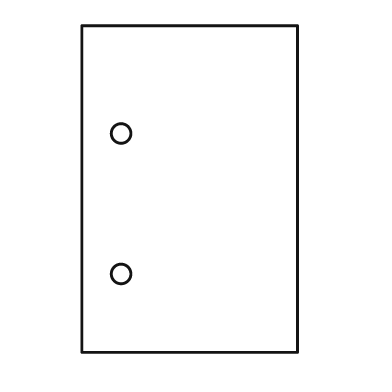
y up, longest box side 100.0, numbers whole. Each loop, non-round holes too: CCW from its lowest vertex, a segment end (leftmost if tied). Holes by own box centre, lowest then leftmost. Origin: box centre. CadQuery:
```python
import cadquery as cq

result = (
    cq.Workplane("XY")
    .moveTo(-33.0, -50.0)
    .lineTo(33.0, -50.0)
    .lineTo(33.0, 50.0)
    .lineTo(-33.0, 50.0)
    .close()
    .moveTo(-21.0, -26.0)
    .circle(3.0)
    .moveTo(-21.0, 17.0)
    .circle(3.0)
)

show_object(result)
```